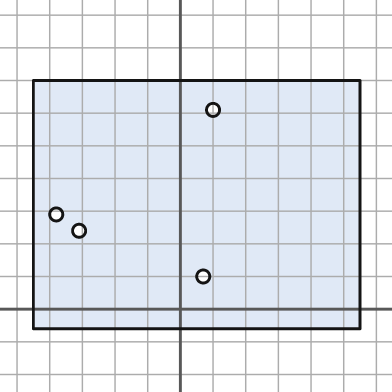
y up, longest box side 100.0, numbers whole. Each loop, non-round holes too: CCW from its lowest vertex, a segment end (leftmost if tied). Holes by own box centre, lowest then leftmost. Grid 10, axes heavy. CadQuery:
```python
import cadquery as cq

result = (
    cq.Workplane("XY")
    .moveTo(-45.0, -6.0)
    .lineTo(55.0, -6.0)
    .lineTo(55.0, 70.0)
    .lineTo(-45.0, 70.0)
    .close()
    .moveTo(7.0, 10.0)
    .circle(2.0)
    .moveTo(-31.0, 24.0)
    .circle(2.0)
    .moveTo(-38.0, 29.0)
    .circle(2.0)
    .moveTo(10.0, 61.0)
    .circle(2.0)
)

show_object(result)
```